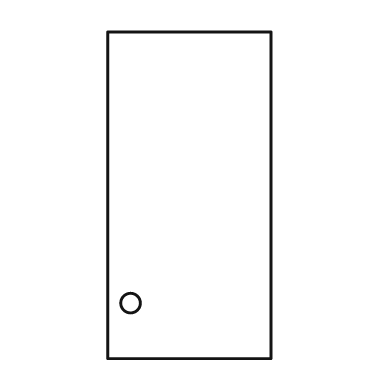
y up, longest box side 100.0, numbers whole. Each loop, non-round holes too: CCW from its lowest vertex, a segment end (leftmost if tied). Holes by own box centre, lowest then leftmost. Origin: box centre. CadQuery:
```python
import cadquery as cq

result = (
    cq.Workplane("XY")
    .moveTo(-25.0, -50.0)
    .lineTo(25.0, -50.0)
    .lineTo(25.0, 50.0)
    .lineTo(-25.0, 50.0)
    .close()
    .moveTo(-18.0, -33.0)
    .circle(3.0)
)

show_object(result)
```